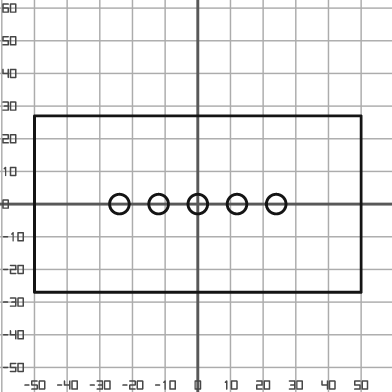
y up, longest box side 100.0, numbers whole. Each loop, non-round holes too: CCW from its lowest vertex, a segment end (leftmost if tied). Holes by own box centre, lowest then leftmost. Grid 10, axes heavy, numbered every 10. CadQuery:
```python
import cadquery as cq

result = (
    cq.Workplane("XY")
    .moveTo(-50.0, -27.0)
    .lineTo(50.0, -27.0)
    .lineTo(50.0, 27.0)
    .lineTo(-50.0, 27.0)
    .close()
    .moveTo(-24.0, 0.0)
    .circle(3.0)
    .moveTo(-12.0, 0.0)
    .circle(3.0)
    .moveTo(0.0, 0.0)
    .circle(3.0)
    .moveTo(12.0, 0.0)
    .circle(3.0)
    .moveTo(24.0, 0.0)
    .circle(3.0)
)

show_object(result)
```